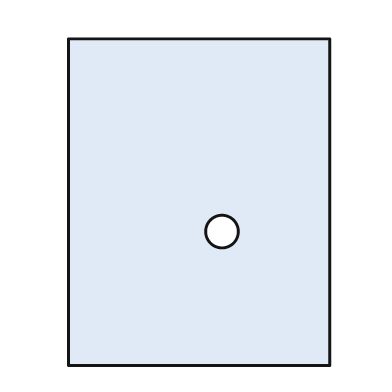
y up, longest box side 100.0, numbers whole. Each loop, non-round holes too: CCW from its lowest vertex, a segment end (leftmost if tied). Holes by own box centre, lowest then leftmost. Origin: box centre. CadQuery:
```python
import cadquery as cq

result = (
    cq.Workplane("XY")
    .moveTo(-40.0, -50.0)
    .lineTo(40.0, -50.0)
    .lineTo(40.0, 50.0)
    .lineTo(-40.0, 50.0)
    .close()
    .moveTo(7.0, -9.0)
    .circle(5.0)
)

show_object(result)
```